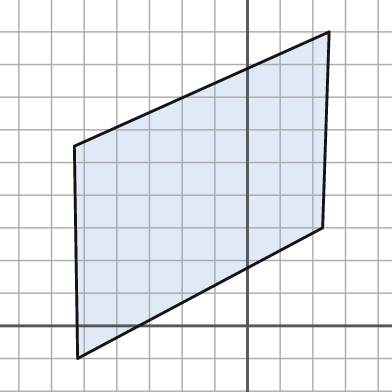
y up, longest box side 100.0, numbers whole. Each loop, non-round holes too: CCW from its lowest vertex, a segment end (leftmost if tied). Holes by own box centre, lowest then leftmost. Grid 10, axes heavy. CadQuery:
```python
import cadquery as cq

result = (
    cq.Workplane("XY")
    .moveTo(-52.0, -10.0)
    .lineTo(23.0, 30.0)
    .lineTo(25.0, 90.0)
    .lineTo(-53.0, 55.0)
    .close()
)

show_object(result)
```